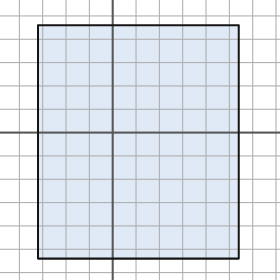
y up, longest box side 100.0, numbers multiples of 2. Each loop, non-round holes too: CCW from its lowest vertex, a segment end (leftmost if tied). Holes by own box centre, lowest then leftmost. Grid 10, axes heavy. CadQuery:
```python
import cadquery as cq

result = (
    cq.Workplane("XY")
    .moveTo(-32.0, -54.0)
    .lineTo(54.0, -54.0)
    .lineTo(54.0, 46.0)
    .lineTo(-32.0, 46.0)
    .close()
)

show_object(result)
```